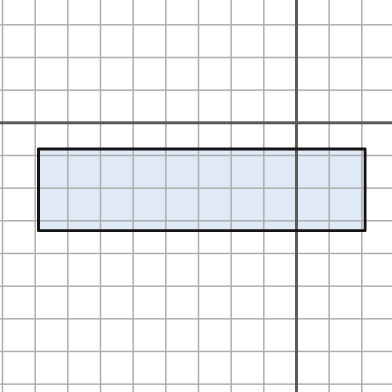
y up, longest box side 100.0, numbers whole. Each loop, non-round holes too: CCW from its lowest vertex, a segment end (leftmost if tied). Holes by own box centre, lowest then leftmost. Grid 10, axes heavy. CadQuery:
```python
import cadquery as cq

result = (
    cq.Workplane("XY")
    .moveTo(-79.0, -33.0)
    .lineTo(21.0, -33.0)
    .lineTo(21.0, -8.0)
    .lineTo(-79.0, -8.0)
    .close()
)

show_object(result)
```